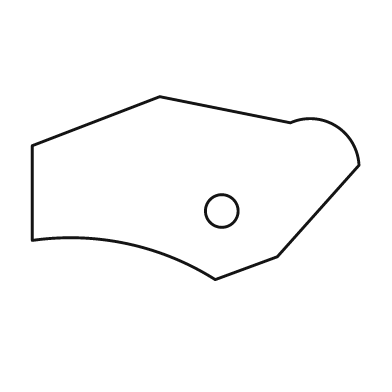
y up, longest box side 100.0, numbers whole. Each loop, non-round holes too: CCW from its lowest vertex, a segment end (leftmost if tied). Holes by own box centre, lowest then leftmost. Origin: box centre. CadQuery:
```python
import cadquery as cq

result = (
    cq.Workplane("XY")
    .moveTo(6.0, -28.0)
    .lineTo(25.0, -21.0)
    .lineTo(50.0, 7.0)
    .threePointArc((43.0, 19.0), (29.0, 20.0))
    .lineTo(-11.0, 28.0)
    .lineTo(-50.0, 13.0)
    .lineTo(-50.0, -16.0)
    .threePointArc((-21.0, -17.0), (6.0, -28.0))
    .close()
    .moveTo(8.0, -7.0)
    .circle(5.0)
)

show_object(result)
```